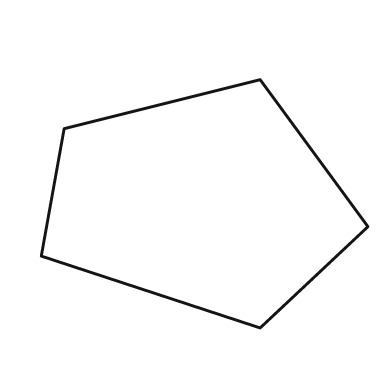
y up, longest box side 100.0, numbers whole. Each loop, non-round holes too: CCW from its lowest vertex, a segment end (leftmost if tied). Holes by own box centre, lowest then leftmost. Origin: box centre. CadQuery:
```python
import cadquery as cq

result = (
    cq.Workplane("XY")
    .moveTo(17.0, -38.0)
    .lineTo(50.0, -7.0)
    .lineTo(17.0, 38.0)
    .lineTo(-43.0, 23.0)
    .lineTo(-50.0, -16.0)
    .close()
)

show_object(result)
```